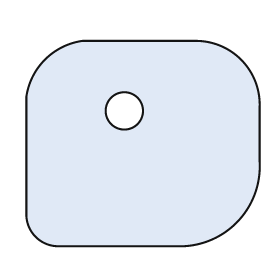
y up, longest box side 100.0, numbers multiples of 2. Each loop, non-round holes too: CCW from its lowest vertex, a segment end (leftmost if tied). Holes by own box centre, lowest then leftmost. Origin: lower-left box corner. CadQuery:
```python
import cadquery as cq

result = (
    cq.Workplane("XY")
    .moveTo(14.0, 0.0)
    .lineTo(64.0, 0.0)
    .threePointArc((90.0, 10.0), (100.0, 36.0))
    .lineTo(100.0, 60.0)
    .threePointArc((92.0, 80.0), (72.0, 88.0))
    .lineTo(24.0, 88.0)
    .threePointArc((8.0, 80.0), (0.0, 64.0))
    .lineTo(0.0, 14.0)
    .threePointArc((4.0, 4.0), (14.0, 0.0))
    .close()
    .moveTo(42.0, 58.0)
    .circle(8.0)
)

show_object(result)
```